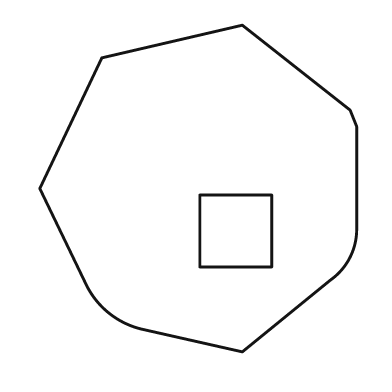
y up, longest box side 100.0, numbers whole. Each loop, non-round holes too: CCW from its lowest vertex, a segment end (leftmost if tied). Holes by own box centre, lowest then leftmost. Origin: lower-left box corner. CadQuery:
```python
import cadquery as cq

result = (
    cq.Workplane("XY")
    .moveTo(62.0, 0.0)
    .lineTo(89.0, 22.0)
    .threePointArc((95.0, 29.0), (97.0, 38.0))
    .lineTo(97.0, 69.0)
    .lineTo(95.0, 74.0)
    .lineTo(62.0, 100.0)
    .lineTo(19.0, 90.0)
    .lineTo(0.0, 50.0)
    .lineTo(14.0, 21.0)
    .threePointArc((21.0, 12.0), (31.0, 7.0))
    .close()
    .moveTo(49.0, 26.0)
    .lineTo(71.0, 26.0)
    .lineTo(71.0, 48.0)
    .lineTo(49.0, 48.0)
    .close()
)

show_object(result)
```